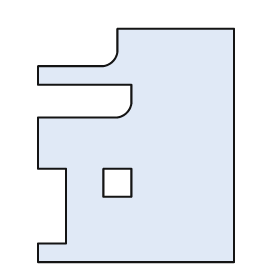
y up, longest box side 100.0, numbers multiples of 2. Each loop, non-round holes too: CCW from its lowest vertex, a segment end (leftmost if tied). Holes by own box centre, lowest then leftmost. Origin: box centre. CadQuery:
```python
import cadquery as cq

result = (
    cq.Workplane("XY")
    .moveTo(-42.0, -50.0)
    .lineTo(42.0, -50.0)
    .lineTo(42.0, 50.0)
    .lineTo(-8.0, 50.0)
    .lineTo(-8.0, 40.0)
    .threePointArc((-10.0, 36.0), (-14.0, 34.0))
    .lineTo(-42.0, 34.0)
    .lineTo(-42.0, 26.0)
    .lineTo(-2.0, 26.0)
    .lineTo(-2.0, 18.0)
    .threePointArc((-4.0, 14.0), (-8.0, 12.0))
    .lineTo(-42.0, 12.0)
    .lineTo(-42.0, -10.0)
    .lineTo(-30.0, -10.0)
    .lineTo(-30.0, -42.0)
    .lineTo(-42.0, -42.0)
    .close()
    .moveTo(-14.0, -22.0)
    .lineTo(-2.0, -22.0)
    .lineTo(-2.0, -10.0)
    .lineTo(-14.0, -10.0)
    .close()
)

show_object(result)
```